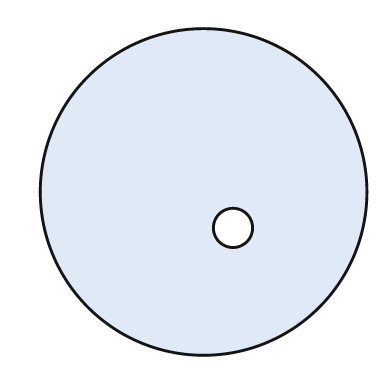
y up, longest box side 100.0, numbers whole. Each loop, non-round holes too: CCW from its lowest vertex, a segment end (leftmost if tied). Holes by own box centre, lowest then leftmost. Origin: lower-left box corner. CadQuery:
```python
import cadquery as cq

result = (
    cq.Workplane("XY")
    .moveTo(50.0, 50.0)
    .circle(50.0)
    .moveTo(59.0, 39.0)
    .circle(6.0)
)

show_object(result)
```